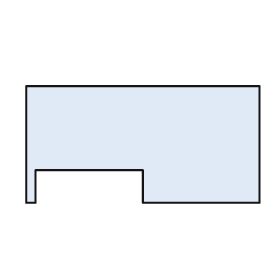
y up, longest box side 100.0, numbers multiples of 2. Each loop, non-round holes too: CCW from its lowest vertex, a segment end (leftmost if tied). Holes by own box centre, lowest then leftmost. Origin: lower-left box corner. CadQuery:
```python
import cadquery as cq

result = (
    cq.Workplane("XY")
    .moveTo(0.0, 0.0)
    .lineTo(4.0, 0.0)
    .lineTo(4.0, 14.0)
    .lineTo(50.0, 14.0)
    .lineTo(50.0, 0.0)
    .lineTo(100.0, 0.0)
    .lineTo(100.0, 50.0)
    .lineTo(0.0, 50.0)
    .close()
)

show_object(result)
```